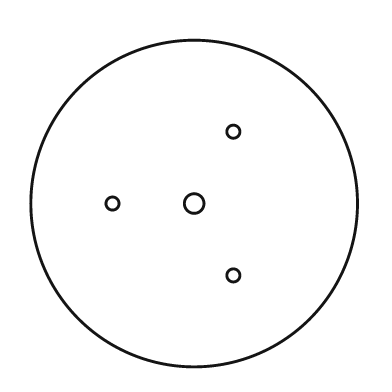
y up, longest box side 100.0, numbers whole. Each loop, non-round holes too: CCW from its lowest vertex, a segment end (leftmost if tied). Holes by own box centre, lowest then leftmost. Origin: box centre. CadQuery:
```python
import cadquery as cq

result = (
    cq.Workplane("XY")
    .moveTo(0.0, 0.0)
    .circle(50.0)
    .moveTo(12.0, -22.0)
    .circle(2.0)
    .moveTo(-25.0, 0.0)
    .circle(2.0)
    .moveTo(0.0, 0.0)
    .circle(3.0)
    .moveTo(12.0, 22.0)
    .circle(2.0)
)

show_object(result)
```